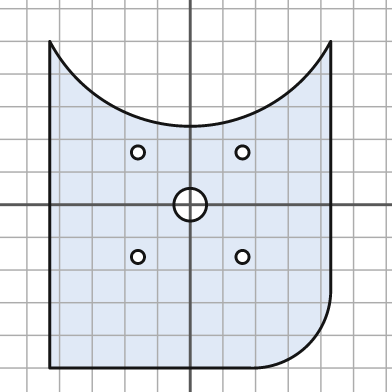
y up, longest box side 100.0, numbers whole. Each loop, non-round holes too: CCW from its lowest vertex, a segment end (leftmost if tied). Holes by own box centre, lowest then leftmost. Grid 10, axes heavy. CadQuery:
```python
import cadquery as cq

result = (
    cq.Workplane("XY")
    .moveTo(-43.0, -50.0)
    .lineTo(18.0, -50.0)
    .threePointArc((36.0, -43.0), (43.0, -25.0))
    .lineTo(43.0, 50.0)
    .threePointArc((0.0, 24.0), (-43.0, 50.0))
    .close()
    .moveTo(-16.0, -16.0)
    .circle(2.0)
    .moveTo(16.0, -16.0)
    .circle(2.0)
    .moveTo(0.0, 0.0)
    .circle(5.0)
    .moveTo(-16.0, 16.0)
    .circle(2.0)
    .moveTo(16.0, 16.0)
    .circle(2.0)
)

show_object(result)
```